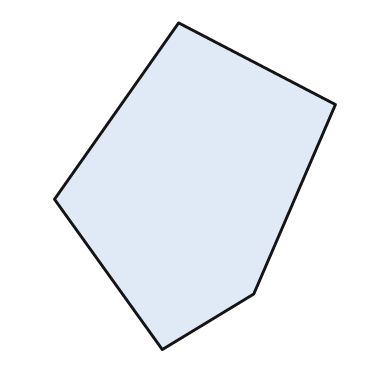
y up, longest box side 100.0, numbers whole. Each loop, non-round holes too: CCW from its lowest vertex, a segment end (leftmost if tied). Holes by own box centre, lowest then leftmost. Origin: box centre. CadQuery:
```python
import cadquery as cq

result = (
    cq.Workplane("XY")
    .moveTo(-10.0, -50.0)
    .lineTo(18.0, -33.0)
    .lineTo(43.0, 25.0)
    .lineTo(-5.0, 50.0)
    .lineTo(-43.0, -4.0)
    .close()
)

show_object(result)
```